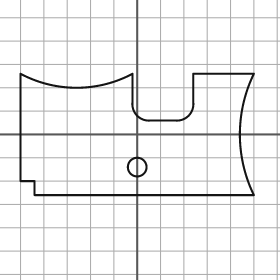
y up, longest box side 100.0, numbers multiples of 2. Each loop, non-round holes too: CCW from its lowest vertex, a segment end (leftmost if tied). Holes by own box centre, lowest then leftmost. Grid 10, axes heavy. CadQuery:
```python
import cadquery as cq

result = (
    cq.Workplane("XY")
    .moveTo(-44.0, -26.0)
    .lineTo(50.0, -26.0)
    .threePointArc((44.0, 0.0), (50.0, 26.0))
    .lineTo(24.0, 26.0)
    .lineTo(24.0, 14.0)
    .threePointArc((22.0, 8.0), (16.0, 6.0))
    .lineTo(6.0, 6.0)
    .threePointArc((0.0, 8.0), (-2.0, 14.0))
    .lineTo(-2.0, 26.0)
    .threePointArc((-26.0, 20.0), (-50.0, 26.0))
    .lineTo(-50.0, -20.0)
    .lineTo(-44.0, -20.0)
    .close()
    .moveTo(0.0, -14.0)
    .circle(4.0)
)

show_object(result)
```